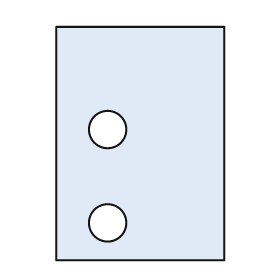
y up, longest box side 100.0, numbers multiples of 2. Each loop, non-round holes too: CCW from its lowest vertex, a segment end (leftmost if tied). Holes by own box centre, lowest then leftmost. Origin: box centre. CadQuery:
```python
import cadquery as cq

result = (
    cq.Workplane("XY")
    .moveTo(-36.0, -50.0)
    .lineTo(36.0, -50.0)
    .lineTo(36.0, 50.0)
    .lineTo(-36.0, 50.0)
    .close()
    .moveTo(-14.0, -34.0)
    .circle(8.0)
    .moveTo(-14.0, 6.0)
    .circle(8.0)
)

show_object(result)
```